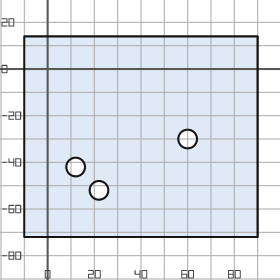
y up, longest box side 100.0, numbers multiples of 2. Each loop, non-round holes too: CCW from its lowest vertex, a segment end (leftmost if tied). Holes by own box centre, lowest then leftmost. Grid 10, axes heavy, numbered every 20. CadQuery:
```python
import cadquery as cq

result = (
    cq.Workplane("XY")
    .moveTo(-10.0, -72.0)
    .lineTo(90.0, -72.0)
    .lineTo(90.0, 14.0)
    .lineTo(-10.0, 14.0)
    .close()
    .moveTo(22.0, -52.0)
    .circle(4.0)
    .moveTo(12.0, -42.0)
    .circle(4.0)
    .moveTo(60.0, -30.0)
    .circle(4.0)
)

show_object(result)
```